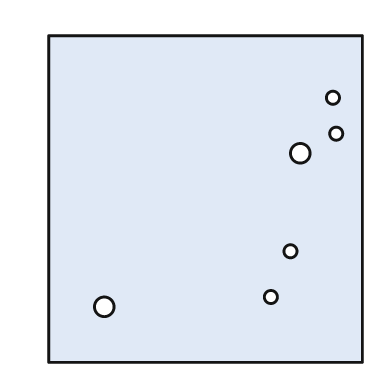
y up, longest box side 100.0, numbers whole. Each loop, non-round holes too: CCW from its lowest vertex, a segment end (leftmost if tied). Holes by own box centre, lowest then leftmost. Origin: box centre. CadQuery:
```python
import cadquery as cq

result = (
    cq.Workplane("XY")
    .moveTo(-48.0, -50.0)
    .lineTo(48.0, -50.0)
    .lineTo(48.0, 50.0)
    .lineTo(-48.0, 50.0)
    .close()
    .moveTo(-31.0, -33.0)
    .circle(3.0)
    .moveTo(20.0, -30.0)
    .circle(2.0)
    .moveTo(26.0, -16.0)
    .circle(2.0)
    .moveTo(29.0, 14.0)
    .circle(3.0)
    .moveTo(40.0, 20.0)
    .circle(2.0)
    .moveTo(39.0, 31.0)
    .circle(2.0)
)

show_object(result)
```